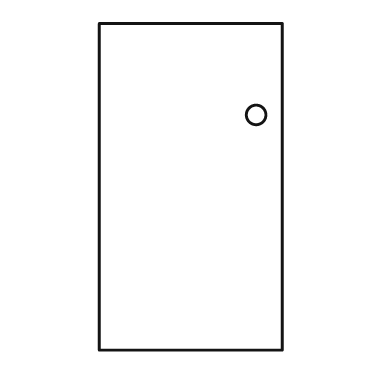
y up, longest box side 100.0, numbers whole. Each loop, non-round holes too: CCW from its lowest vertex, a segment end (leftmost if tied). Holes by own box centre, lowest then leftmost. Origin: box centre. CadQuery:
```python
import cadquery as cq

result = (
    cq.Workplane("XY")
    .moveTo(-28.0, -50.0)
    .lineTo(28.0, -50.0)
    .lineTo(28.0, 50.0)
    .lineTo(-28.0, 50.0)
    .close()
    .moveTo(20.0, 22.0)
    .circle(3.0)
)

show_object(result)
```